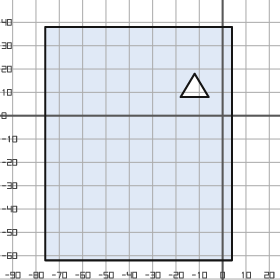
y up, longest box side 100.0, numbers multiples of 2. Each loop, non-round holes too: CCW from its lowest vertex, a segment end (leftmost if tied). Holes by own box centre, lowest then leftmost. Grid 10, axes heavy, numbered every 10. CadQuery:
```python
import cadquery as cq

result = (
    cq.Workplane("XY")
    .moveTo(-76.0, -62.0)
    .lineTo(4.0, -62.0)
    .lineTo(4.0, 38.0)
    .lineTo(-76.0, 38.0)
    .close()
    .moveTo(-18.0, 8.0)
    .lineTo(-6.0, 8.0)
    .lineTo(-12.0, 18.0)
    .close()
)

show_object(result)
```